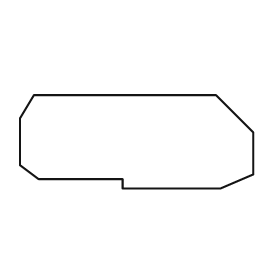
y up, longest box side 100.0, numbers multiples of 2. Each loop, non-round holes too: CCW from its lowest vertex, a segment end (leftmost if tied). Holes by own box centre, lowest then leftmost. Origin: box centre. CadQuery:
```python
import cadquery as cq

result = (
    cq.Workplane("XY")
    .moveTo(-6.0, -20.0)
    .lineTo(36.0, -20.0)
    .lineTo(50.0, -14.0)
    .lineTo(50.0, 4.0)
    .lineTo(34.0, 20.0)
    .lineTo(-44.0, 20.0)
    .lineTo(-50.0, 10.0)
    .lineTo(-50.0, -10.0)
    .lineTo(-42.0, -16.0)
    .lineTo(-6.0, -16.0)
    .close()
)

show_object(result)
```